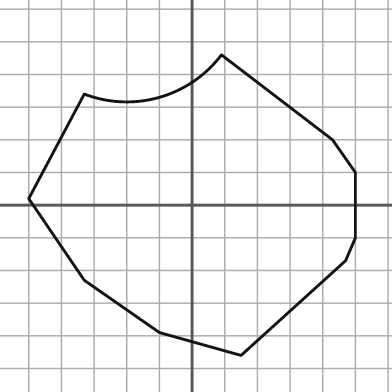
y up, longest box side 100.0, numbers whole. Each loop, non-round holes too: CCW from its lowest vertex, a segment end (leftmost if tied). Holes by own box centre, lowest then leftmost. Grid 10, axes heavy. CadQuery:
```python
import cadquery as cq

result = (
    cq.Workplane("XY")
    .moveTo(15.0, -46.0)
    .lineTo(47.0, -17.0)
    .lineTo(50.0, -10.0)
    .lineTo(50.0, 10.0)
    .lineTo(43.0, 20.0)
    .lineTo(9.0, 46.0)
    .threePointArc((-10.0, 33.0), (-33.0, 34.0))
    .lineTo(-50.0, 2.0)
    .lineTo(-33.0, -23.0)
    .lineTo(-10.0, -39.0)
    .close()
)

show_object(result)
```